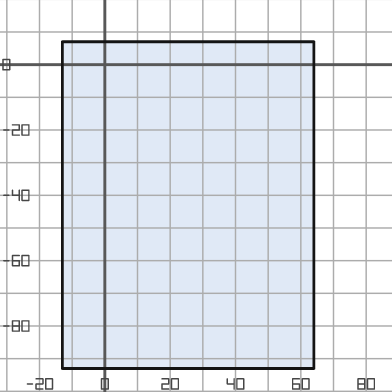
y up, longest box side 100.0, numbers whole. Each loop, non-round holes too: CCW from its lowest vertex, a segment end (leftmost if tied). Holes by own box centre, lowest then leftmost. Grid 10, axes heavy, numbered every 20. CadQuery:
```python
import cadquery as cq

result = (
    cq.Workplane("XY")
    .moveTo(-13.0, -93.0)
    .lineTo(64.0, -93.0)
    .lineTo(64.0, 7.0)
    .lineTo(-13.0, 7.0)
    .close()
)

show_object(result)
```